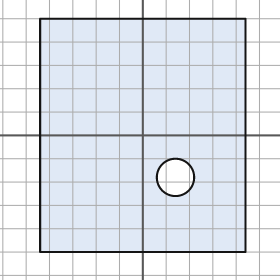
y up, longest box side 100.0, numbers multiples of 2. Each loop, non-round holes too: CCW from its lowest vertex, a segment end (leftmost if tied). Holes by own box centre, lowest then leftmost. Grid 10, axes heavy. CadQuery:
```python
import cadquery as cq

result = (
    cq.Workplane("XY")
    .moveTo(-44.0, -50.0)
    .lineTo(44.0, -50.0)
    .lineTo(44.0, 50.0)
    .lineTo(-44.0, 50.0)
    .close()
    .moveTo(14.0, -18.0)
    .circle(8.0)
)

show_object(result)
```